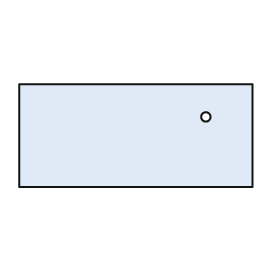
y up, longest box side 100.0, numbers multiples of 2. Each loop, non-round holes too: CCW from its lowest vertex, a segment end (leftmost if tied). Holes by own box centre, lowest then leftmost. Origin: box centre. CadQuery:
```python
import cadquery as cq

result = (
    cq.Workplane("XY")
    .moveTo(-50.0, -22.0)
    .lineTo(50.0, -22.0)
    .lineTo(50.0, 22.0)
    .lineTo(-50.0, 22.0)
    .close()
    .moveTo(30.0, 8.0)
    .circle(2.0)
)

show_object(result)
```